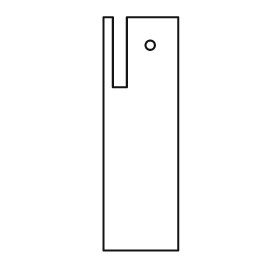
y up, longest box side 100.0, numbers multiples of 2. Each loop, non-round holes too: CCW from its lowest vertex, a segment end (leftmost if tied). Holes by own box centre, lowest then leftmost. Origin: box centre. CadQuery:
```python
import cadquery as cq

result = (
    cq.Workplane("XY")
    .moveTo(-16.0, -50.0)
    .lineTo(16.0, -50.0)
    .lineTo(16.0, 50.0)
    .lineTo(-6.0, 50.0)
    .lineTo(-6.0, 20.0)
    .lineTo(-12.0, 20.0)
    .lineTo(-12.0, 50.0)
    .lineTo(-16.0, 50.0)
    .close()
    .moveTo(4.0, 38.0)
    .circle(2.0)
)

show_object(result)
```